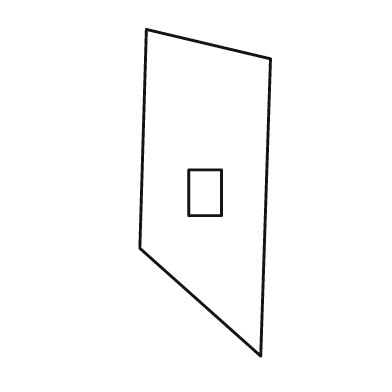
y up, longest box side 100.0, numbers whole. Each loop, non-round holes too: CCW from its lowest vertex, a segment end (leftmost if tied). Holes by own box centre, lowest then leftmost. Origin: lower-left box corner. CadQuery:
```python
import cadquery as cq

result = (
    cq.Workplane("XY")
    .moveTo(37.0, 0.0)
    .lineTo(40.0, 91.0)
    .lineTo(2.0, 100.0)
    .lineTo(0.0, 33.0)
    .close()
    .moveTo(15.0, 43.0)
    .lineTo(25.0, 43.0)
    .lineTo(25.0, 57.0)
    .lineTo(15.0, 57.0)
    .close()
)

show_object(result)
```